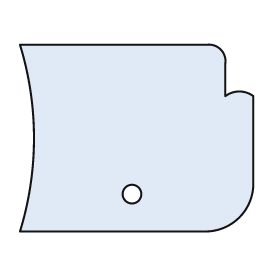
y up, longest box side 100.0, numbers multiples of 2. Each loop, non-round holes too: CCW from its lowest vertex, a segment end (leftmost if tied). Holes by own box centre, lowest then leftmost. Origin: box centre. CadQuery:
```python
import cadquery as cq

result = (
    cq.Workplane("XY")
    .moveTo(-50.0, -40.0)
    .lineTo(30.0, -40.0)
    .threePointArc((44.0, -34.0), (50.0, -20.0))
    .lineTo(50.0, 18.0)
    .threePointArc((44.0, 20.0), (38.0, 18.0))
    .lineTo(38.0, 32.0)
    .threePointArc((36.0, 38.0), (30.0, 40.0))
    .lineTo(-50.0, 40.0)
    .threePointArc((-44.0, 0.0), (-50.0, -40.0))
    .close()
    .moveTo(-2.0, -24.0)
    .circle(4.0)
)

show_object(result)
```